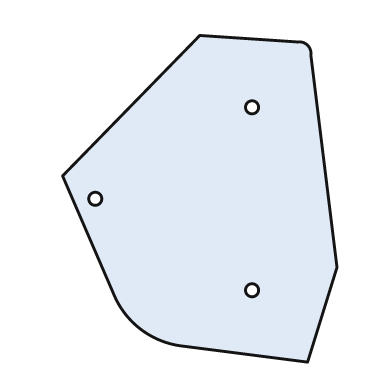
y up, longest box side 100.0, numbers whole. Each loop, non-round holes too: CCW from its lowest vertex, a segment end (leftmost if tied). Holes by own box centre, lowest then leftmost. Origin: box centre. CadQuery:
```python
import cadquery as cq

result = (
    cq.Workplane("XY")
    .moveTo(33.0, -50.0)
    .lineTo(42.0, -21.0)
    .lineTo(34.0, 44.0)
    .threePointArc((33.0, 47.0), (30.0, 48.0))
    .lineTo(0.0, 50.0)
    .lineTo(-42.0, 7.0)
    .lineTo(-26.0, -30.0)
    .threePointArc((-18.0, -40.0), (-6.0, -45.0))
    .close()
    .moveTo(16.0, -28.0)
    .circle(2.0)
    .moveTo(-32.0, 0.0)
    .circle(2.0)
    .moveTo(16.0, 28.0)
    .circle(2.0)
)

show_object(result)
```